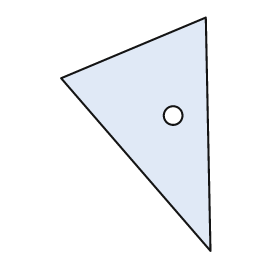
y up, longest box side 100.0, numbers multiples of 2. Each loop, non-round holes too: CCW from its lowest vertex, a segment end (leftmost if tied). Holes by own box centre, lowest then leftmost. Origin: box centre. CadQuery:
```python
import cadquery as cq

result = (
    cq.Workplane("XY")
    .moveTo(32.0, -50.0)
    .lineTo(30.0, 50.0)
    .lineTo(-32.0, 24.0)
    .close()
    .moveTo(16.0, 8.0)
    .circle(4.0)
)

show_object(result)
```